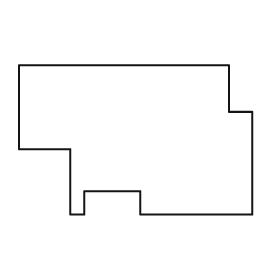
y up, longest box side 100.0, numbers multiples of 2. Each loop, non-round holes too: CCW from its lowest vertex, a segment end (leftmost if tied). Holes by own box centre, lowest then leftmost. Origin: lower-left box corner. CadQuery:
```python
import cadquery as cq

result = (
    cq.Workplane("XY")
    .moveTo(22.0, 0.0)
    .lineTo(28.0, 0.0)
    .lineTo(28.0, 10.0)
    .lineTo(52.0, 10.0)
    .lineTo(52.0, 0.0)
    .lineTo(100.0, 0.0)
    .lineTo(100.0, 44.0)
    .lineTo(90.0, 44.0)
    .lineTo(90.0, 64.0)
    .lineTo(0.0, 64.0)
    .lineTo(0.0, 28.0)
    .lineTo(22.0, 28.0)
    .close()
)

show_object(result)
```